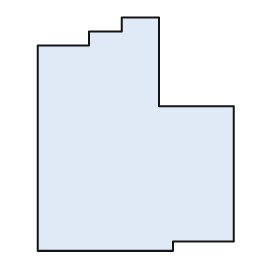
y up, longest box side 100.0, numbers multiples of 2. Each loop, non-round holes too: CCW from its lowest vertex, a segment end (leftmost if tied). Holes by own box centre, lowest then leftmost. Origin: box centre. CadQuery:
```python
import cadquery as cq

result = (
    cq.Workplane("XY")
    .moveTo(-42.0, -50.0)
    .lineTo(16.0, -50.0)
    .lineTo(16.0, -46.0)
    .lineTo(42.0, -46.0)
    .lineTo(42.0, 12.0)
    .lineTo(10.0, 12.0)
    .lineTo(10.0, 50.0)
    .lineTo(-6.0, 50.0)
    .lineTo(-6.0, 44.0)
    .lineTo(-20.0, 44.0)
    .lineTo(-20.0, 38.0)
    .lineTo(-42.0, 38.0)
    .close()
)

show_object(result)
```